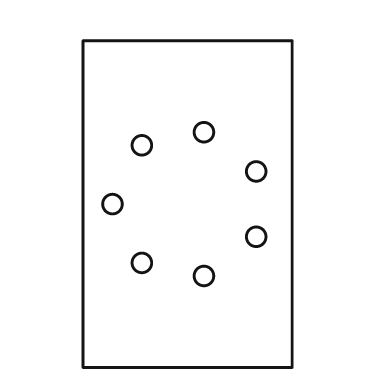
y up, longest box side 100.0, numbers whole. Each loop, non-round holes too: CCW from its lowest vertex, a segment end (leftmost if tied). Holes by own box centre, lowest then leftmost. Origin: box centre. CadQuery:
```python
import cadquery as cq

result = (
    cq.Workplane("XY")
    .moveTo(-32.0, -50.0)
    .lineTo(32.0, -50.0)
    .lineTo(32.0, 50.0)
    .lineTo(-32.0, 50.0)
    .close()
    .moveTo(5.0, -22.0)
    .circle(3.0)
    .moveTo(-14.0, -18.0)
    .circle(3.0)
    .moveTo(21.0, -10.0)
    .circle(3.0)
    .moveTo(-23.0, 0.0)
    .circle(3.0)
    .moveTo(21.0, 10.0)
    .circle(3.0)
    .moveTo(-14.0, 18.0)
    .circle(3.0)
    .moveTo(5.0, 22.0)
    .circle(3.0)
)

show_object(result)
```